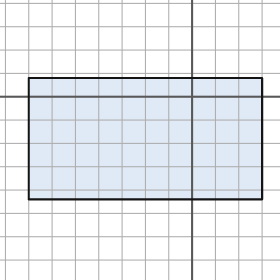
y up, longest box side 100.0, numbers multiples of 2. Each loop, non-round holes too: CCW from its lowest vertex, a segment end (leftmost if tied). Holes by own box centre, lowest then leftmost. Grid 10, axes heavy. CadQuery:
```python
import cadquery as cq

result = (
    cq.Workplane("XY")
    .moveTo(-70.0, -44.0)
    .lineTo(30.0, -44.0)
    .lineTo(30.0, 8.0)
    .lineTo(-70.0, 8.0)
    .close()
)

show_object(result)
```